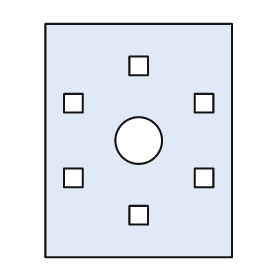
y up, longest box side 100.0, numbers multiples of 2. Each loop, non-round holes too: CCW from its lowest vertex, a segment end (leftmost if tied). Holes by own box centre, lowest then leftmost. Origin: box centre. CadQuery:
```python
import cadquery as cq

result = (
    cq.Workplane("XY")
    .moveTo(-40.0, -50.0)
    .lineTo(40.0, -50.0)
    .lineTo(40.0, 50.0)
    .lineTo(-40.0, 50.0)
    .close()
    .moveTo(-4.0, -36.0)
    .lineTo(4.0, -36.0)
    .lineTo(4.0, -28.0)
    .lineTo(-4.0, -28.0)
    .close()
    .moveTo(-32.0, -20.0)
    .lineTo(-24.0, -20.0)
    .lineTo(-24.0, -12.0)
    .lineTo(-32.0, -12.0)
    .close()
    .moveTo(24.0, -20.0)
    .lineTo(32.0, -20.0)
    .lineTo(32.0, -12.0)
    .lineTo(24.0, -12.0)
    .close()
    .moveTo(0.0, 0.0)
    .circle(10.0)
    .moveTo(-32.0, 12.0)
    .lineTo(-24.0, 12.0)
    .lineTo(-24.0, 20.0)
    .lineTo(-32.0, 20.0)
    .close()
    .moveTo(24.0, 12.0)
    .lineTo(32.0, 12.0)
    .lineTo(32.0, 20.0)
    .lineTo(24.0, 20.0)
    .close()
    .moveTo(-4.0, 28.0)
    .lineTo(4.0, 28.0)
    .lineTo(4.0, 36.0)
    .lineTo(-4.0, 36.0)
    .close()
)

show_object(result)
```